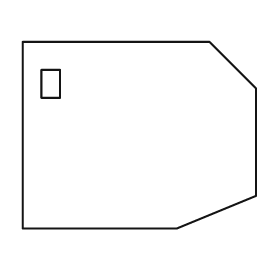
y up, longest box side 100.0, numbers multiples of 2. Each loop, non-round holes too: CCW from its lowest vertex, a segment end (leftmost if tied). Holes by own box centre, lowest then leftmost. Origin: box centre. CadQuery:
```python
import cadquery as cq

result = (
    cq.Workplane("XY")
    .moveTo(-50.0, -40.0)
    .lineTo(16.0, -40.0)
    .lineTo(50.0, -26.0)
    .lineTo(50.0, 20.0)
    .lineTo(30.0, 40.0)
    .lineTo(-50.0, 40.0)
    .close()
    .moveTo(-42.0, 16.0)
    .lineTo(-34.0, 16.0)
    .lineTo(-34.0, 28.0)
    .lineTo(-42.0, 28.0)
    .close()
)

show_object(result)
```